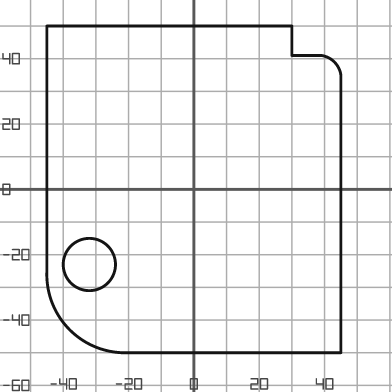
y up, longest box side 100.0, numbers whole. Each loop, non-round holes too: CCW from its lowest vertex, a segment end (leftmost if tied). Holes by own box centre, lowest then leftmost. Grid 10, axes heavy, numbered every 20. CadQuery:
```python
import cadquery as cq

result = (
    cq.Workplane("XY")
    .moveTo(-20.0, -50.0)
    .lineTo(45.0, -50.0)
    .lineTo(45.0, 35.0)
    .threePointArc((43.0, 39.0), (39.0, 41.0))
    .lineTo(30.0, 41.0)
    .lineTo(30.0, 50.0)
    .lineTo(-45.0, 50.0)
    .lineTo(-45.0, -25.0)
    .threePointArc((-38.0, -43.0), (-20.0, -50.0))
    .close()
    .moveTo(-32.0, -23.0)
    .circle(8.0)
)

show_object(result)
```